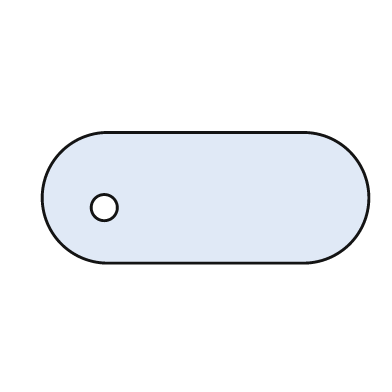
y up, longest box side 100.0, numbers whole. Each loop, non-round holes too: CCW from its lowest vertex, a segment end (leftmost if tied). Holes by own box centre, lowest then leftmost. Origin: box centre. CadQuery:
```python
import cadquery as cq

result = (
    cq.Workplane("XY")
    .moveTo(-30.0, -20.0)
    .lineTo(30.0, -20.0)
    .threePointArc((50.0, 0.0), (30.0, 20.0))
    .lineTo(-30.0, 20.0)
    .threePointArc((-50.0, 0.0), (-30.0, -20.0))
    .close()
    .moveTo(-31.0, -3.0)
    .circle(4.0)
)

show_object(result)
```